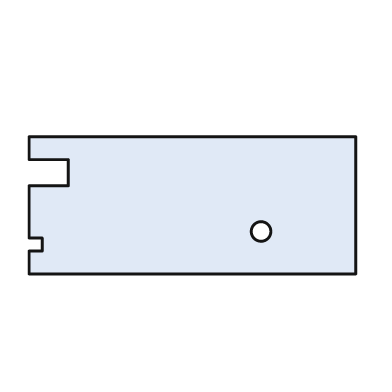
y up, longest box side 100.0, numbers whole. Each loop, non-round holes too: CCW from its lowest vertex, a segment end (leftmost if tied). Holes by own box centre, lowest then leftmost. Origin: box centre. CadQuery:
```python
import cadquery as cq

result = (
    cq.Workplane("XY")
    .moveTo(-50.0, -21.0)
    .lineTo(50.0, -21.0)
    .lineTo(50.0, 21.0)
    .lineTo(-50.0, 21.0)
    .lineTo(-50.0, 14.0)
    .lineTo(-38.0, 14.0)
    .lineTo(-38.0, 6.0)
    .lineTo(-50.0, 6.0)
    .lineTo(-50.0, -10.0)
    .lineTo(-46.0, -10.0)
    .lineTo(-46.0, -14.0)
    .lineTo(-50.0, -14.0)
    .close()
    .moveTo(21.0, -8.0)
    .circle(3.0)
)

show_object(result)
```